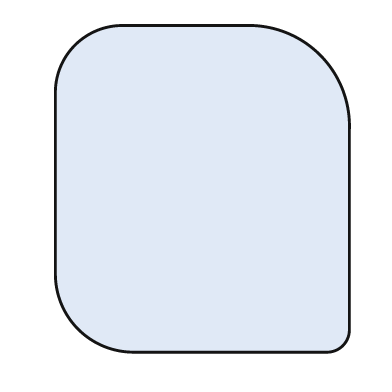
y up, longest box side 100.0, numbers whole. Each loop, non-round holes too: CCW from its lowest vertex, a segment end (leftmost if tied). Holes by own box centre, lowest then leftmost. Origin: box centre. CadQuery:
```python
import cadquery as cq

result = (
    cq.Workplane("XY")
    .moveTo(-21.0, -50.0)
    .lineTo(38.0, -50.0)
    .threePointArc((43.0, -48.0), (45.0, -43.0))
    .lineTo(45.0, 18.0)
    .threePointArc((36.0, 41.0), (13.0, 50.0))
    .lineTo(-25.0, 50.0)
    .threePointArc((-39.0, 44.0), (-45.0, 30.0))
    .lineTo(-45.0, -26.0)
    .threePointArc((-38.0, -43.0), (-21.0, -50.0))
    .close()
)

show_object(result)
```